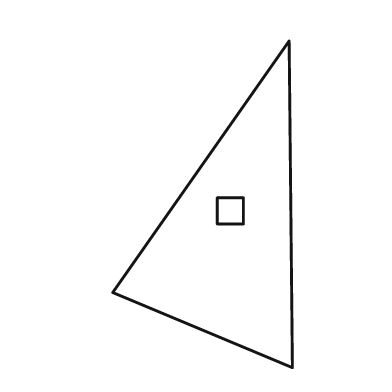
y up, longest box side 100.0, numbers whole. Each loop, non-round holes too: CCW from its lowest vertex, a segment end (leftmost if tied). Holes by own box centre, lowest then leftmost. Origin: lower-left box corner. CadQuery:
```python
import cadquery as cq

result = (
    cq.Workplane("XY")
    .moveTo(55.0, 0.0)
    .lineTo(54.0, 100.0)
    .lineTo(0.0, 23.0)
    .close()
    .moveTo(32.0, 44.0)
    .lineTo(40.0, 44.0)
    .lineTo(40.0, 52.0)
    .lineTo(32.0, 52.0)
    .close()
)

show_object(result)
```